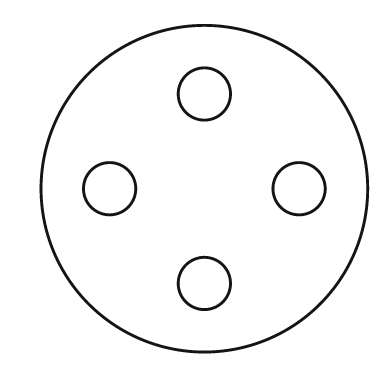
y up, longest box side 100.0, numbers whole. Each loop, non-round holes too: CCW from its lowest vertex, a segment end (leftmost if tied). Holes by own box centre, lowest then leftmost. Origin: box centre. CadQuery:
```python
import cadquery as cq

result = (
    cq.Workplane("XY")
    .moveTo(0.0, 0.0)
    .circle(50.0)
    .moveTo(0.0, -29.0)
    .circle(8.0)
    .moveTo(-29.0, 0.0)
    .circle(8.0)
    .moveTo(29.0, 0.0)
    .circle(8.0)
    .moveTo(0.0, 29.0)
    .circle(8.0)
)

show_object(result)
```